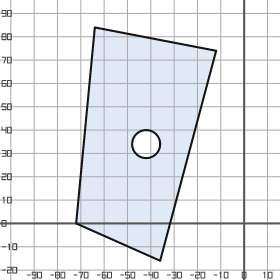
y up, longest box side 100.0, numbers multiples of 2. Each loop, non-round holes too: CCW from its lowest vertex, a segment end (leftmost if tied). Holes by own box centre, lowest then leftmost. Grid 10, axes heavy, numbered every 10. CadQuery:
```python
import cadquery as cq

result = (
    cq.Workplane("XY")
    .moveTo(-36.0, -16.0)
    .lineTo(-12.0, 74.0)
    .lineTo(-64.0, 84.0)
    .lineTo(-72.0, 0.0)
    .close()
    .moveTo(-42.0, 34.0)
    .circle(6.0)
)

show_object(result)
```